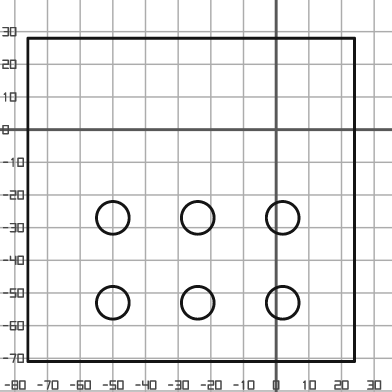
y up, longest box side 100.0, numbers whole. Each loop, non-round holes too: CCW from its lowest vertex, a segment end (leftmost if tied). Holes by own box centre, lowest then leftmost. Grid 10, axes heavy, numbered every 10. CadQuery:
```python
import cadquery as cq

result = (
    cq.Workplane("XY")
    .moveTo(-76.0, -71.0)
    .lineTo(24.0, -71.0)
    .lineTo(24.0, 28.0)
    .lineTo(-76.0, 28.0)
    .close()
    .moveTo(-50.0, -53.0)
    .circle(5.0)
    .moveTo(-24.0, -53.0)
    .circle(5.0)
    .moveTo(2.0, -53.0)
    .circle(5.0)
    .moveTo(-50.0, -27.0)
    .circle(5.0)
    .moveTo(-24.0, -27.0)
    .circle(5.0)
    .moveTo(2.0, -27.0)
    .circle(5.0)
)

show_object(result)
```